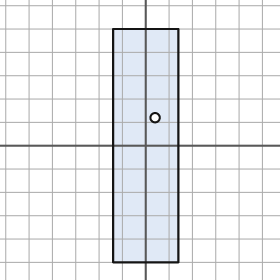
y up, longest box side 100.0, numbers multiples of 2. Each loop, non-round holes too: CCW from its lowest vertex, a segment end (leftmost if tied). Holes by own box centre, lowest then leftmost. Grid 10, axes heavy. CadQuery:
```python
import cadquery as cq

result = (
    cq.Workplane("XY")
    .moveTo(-14.0, -50.0)
    .lineTo(14.0, -50.0)
    .lineTo(14.0, 50.0)
    .lineTo(-14.0, 50.0)
    .close()
    .moveTo(4.0, 12.0)
    .circle(2.0)
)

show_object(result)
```